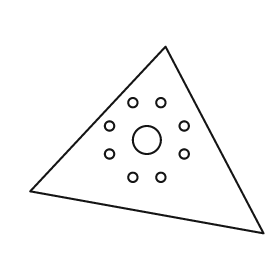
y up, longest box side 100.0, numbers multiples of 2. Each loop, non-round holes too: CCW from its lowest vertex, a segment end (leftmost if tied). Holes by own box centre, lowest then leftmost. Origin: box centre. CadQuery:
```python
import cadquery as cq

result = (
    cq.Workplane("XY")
    .moveTo(50.0, -40.0)
    .lineTo(8.0, 40.0)
    .lineTo(-50.0, -22.0)
    .close()
    .moveTo(-6.0, -16.0)
    .circle(2.0)
    .moveTo(6.0, -16.0)
    .circle(2.0)
    .moveTo(-16.0, -6.0)
    .circle(2.0)
    .moveTo(16.0, -6.0)
    .circle(2.0)
    .moveTo(0.0, 0.0)
    .circle(6.0)
    .moveTo(-16.0, 6.0)
    .circle(2.0)
    .moveTo(16.0, 6.0)
    .circle(2.0)
    .moveTo(-6.0, 16.0)
    .circle(2.0)
    .moveTo(6.0, 16.0)
    .circle(2.0)
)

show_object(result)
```